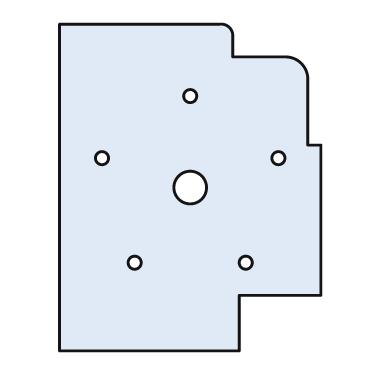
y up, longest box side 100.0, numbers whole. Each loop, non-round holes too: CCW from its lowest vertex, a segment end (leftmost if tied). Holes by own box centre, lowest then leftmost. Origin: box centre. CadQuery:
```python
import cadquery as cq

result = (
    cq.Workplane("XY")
    .moveTo(-40.0, -50.0)
    .lineTo(15.0, -50.0)
    .lineTo(15.0, -33.0)
    .lineTo(40.0, -33.0)
    .lineTo(40.0, 13.0)
    .lineTo(36.0, 13.0)
    .lineTo(36.0, 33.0)
    .threePointArc((34.0, 38.0), (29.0, 40.0))
    .lineTo(13.0, 40.0)
    .lineTo(13.0, 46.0)
    .threePointArc((12.0, 49.0), (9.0, 50.0))
    .lineTo(-40.0, 50.0)
    .close()
    .moveTo(-17.0, -23.0)
    .circle(2.0)
    .moveTo(17.0, -23.0)
    .circle(2.0)
    .moveTo(0.0, 0.0)
    .circle(5.0)
    .moveTo(-27.0, 9.0)
    .circle(2.0)
    .moveTo(27.0, 9.0)
    .circle(2.0)
    .moveTo(0.0, 28.0)
    .circle(2.0)
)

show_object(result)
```